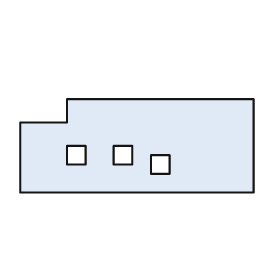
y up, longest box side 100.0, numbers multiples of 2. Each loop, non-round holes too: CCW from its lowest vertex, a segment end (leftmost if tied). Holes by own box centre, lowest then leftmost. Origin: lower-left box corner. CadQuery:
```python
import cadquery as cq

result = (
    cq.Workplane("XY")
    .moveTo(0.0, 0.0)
    .lineTo(100.0, 0.0)
    .lineTo(100.0, 40.0)
    .lineTo(20.0, 40.0)
    .lineTo(20.0, 30.0)
    .lineTo(0.0, 30.0)
    .close()
    .moveTo(56.0, 8.0)
    .lineTo(64.0, 8.0)
    .lineTo(64.0, 16.0)
    .lineTo(56.0, 16.0)
    .close()
    .moveTo(20.0, 12.0)
    .lineTo(28.0, 12.0)
    .lineTo(28.0, 20.0)
    .lineTo(20.0, 20.0)
    .close()
    .moveTo(40.0, 12.0)
    .lineTo(48.0, 12.0)
    .lineTo(48.0, 20.0)
    .lineTo(40.0, 20.0)
    .close()
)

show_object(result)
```